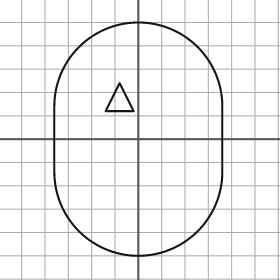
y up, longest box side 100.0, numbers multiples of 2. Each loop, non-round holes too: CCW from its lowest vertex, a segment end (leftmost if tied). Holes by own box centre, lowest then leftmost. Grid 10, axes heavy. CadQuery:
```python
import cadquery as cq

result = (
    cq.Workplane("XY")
    .moveTo(-36.0, -14.0)
    .threePointArc((0.0, -50.0), (36.0, -14.0))
    .lineTo(36.0, 14.0)
    .threePointArc((0.0, 50.0), (-36.0, 14.0))
    .close()
    .moveTo(-14.0, 12.0)
    .lineTo(-2.0, 12.0)
    .lineTo(-8.0, 24.0)
    .close()
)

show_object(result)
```